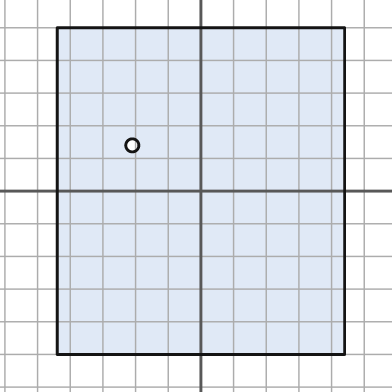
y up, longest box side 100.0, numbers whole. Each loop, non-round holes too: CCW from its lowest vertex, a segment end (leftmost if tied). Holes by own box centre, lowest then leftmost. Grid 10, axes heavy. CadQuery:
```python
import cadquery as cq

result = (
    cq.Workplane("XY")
    .moveTo(-44.0, -50.0)
    .lineTo(44.0, -50.0)
    .lineTo(44.0, 50.0)
    .lineTo(-44.0, 50.0)
    .close()
    .moveTo(-21.0, 14.0)
    .circle(2.0)
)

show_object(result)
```